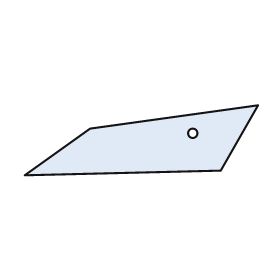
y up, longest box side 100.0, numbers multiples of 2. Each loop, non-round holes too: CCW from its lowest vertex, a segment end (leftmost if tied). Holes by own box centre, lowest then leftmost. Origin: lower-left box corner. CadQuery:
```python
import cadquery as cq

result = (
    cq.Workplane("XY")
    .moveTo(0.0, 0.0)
    .lineTo(84.0, 2.0)
    .lineTo(100.0, 30.0)
    .lineTo(28.0, 20.0)
    .close()
    .moveTo(72.0, 18.0)
    .circle(2.0)
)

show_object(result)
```